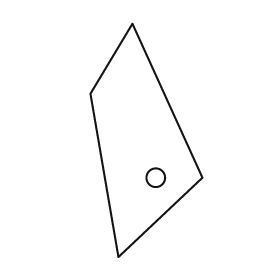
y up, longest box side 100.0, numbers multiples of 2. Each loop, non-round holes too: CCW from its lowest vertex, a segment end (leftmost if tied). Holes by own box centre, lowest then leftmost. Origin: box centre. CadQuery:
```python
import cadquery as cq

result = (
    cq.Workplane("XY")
    .moveTo(-12.0, -50.0)
    .lineTo(24.0, -16.0)
    .lineTo(-6.0, 50.0)
    .lineTo(-24.0, 20.0)
    .close()
    .moveTo(4.0, -16.0)
    .circle(4.0)
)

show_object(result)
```